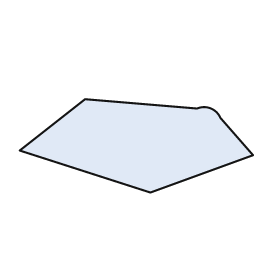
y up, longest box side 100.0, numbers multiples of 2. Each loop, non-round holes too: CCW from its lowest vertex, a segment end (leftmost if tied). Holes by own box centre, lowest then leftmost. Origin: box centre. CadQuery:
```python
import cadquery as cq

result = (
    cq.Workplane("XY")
    .moveTo(6.0, -20.0)
    .lineTo(50.0, -4.0)
    .lineTo(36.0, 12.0)
    .threePointArc((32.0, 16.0), (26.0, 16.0))
    .lineTo(-22.0, 20.0)
    .lineTo(-50.0, -2.0)
    .close()
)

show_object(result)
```